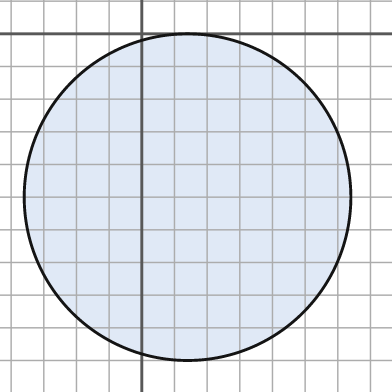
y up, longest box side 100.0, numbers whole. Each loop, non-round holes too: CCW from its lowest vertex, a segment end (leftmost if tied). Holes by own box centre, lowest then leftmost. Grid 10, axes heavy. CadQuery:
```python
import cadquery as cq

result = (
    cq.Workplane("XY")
    .moveTo(14.0, -50.0)
    .circle(50.0)
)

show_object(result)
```